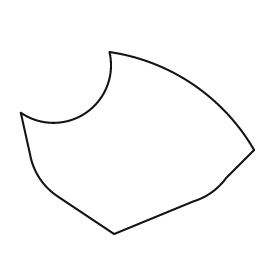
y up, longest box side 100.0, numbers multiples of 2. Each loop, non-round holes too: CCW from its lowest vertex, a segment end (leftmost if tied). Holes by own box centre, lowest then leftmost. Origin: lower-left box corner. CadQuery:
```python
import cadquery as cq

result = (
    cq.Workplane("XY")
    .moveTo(40.0, 0.0)
    .lineTo(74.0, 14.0)
    .threePointArc((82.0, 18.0), (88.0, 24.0))
    .lineTo(100.0, 36.0)
    .threePointArc((74.0, 64.0), (38.0, 78.0))
    .threePointArc((28.0, 52.0), (0.0, 52.0))
    .lineTo(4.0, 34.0)
    .threePointArc((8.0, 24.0), (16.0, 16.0))
    .close()
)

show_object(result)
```